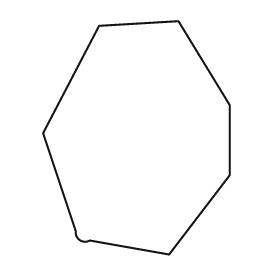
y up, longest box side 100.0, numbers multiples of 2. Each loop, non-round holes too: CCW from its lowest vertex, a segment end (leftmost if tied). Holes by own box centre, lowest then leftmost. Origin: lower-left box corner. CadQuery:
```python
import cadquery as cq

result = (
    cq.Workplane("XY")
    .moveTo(54.0, 0.0)
    .lineTo(80.0, 34.0)
    .lineTo(80.0, 64.0)
    .lineTo(58.0, 100.0)
    .lineTo(24.0, 98.0)
    .lineTo(0.0, 52.0)
    .lineTo(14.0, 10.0)
    .threePointArc((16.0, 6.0), (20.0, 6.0))
    .close()
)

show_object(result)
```